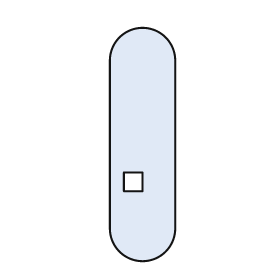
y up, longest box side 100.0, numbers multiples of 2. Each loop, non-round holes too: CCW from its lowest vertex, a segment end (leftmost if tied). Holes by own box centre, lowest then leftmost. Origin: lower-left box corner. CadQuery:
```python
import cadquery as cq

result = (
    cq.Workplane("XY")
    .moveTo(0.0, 14.0)
    .threePointArc((14.0, 0.0), (28.0, 14.0))
    .lineTo(28.0, 86.0)
    .threePointArc((14.0, 100.0), (0.0, 86.0))
    .close()
    .moveTo(6.0, 30.0)
    .lineTo(14.0, 30.0)
    .lineTo(14.0, 38.0)
    .lineTo(6.0, 38.0)
    .close()
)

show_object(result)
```